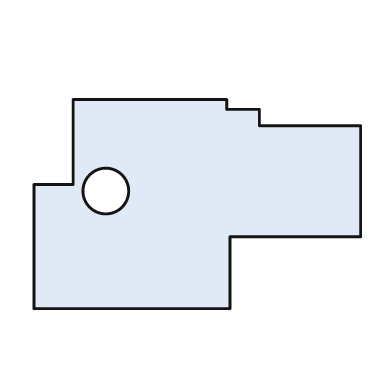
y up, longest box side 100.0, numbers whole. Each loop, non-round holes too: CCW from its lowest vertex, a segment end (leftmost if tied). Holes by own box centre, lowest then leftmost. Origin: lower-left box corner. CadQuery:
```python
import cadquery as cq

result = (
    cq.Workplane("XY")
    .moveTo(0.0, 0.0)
    .lineTo(60.0, 0.0)
    .lineTo(60.0, 22.0)
    .lineTo(100.0, 22.0)
    .lineTo(100.0, 56.0)
    .lineTo(69.0, 56.0)
    .lineTo(69.0, 61.0)
    .lineTo(59.0, 61.0)
    .lineTo(59.0, 64.0)
    .lineTo(12.0, 64.0)
    .lineTo(12.0, 38.0)
    .lineTo(0.0, 38.0)
    .close()
    .moveTo(22.0, 36.0)
    .circle(7.0)
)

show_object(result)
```